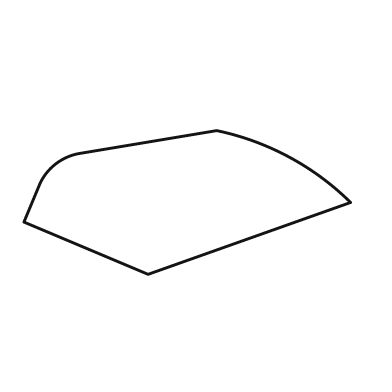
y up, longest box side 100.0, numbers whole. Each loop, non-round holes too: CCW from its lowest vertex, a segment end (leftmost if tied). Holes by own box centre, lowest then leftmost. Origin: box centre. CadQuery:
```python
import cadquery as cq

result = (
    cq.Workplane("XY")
    .moveTo(-12.0, -22.0)
    .lineTo(50.0, 0.0)
    .threePointArc((31.0, 14.0), (9.0, 22.0))
    .lineTo(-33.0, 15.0)
    .threePointArc((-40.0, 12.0), (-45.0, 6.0))
    .lineTo(-50.0, -6.0)
    .close()
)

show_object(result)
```